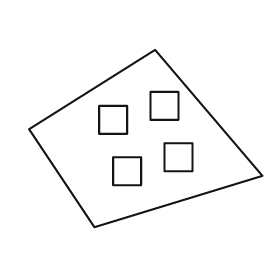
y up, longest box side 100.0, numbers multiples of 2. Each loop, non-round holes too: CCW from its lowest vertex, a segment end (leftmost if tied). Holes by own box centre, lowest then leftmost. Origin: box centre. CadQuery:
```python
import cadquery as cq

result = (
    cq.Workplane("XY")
    .moveTo(-22.0, -38.0)
    .lineTo(50.0, -16.0)
    .lineTo(4.0, 38.0)
    .lineTo(-50.0, 4.0)
    .close()
    .moveTo(-14.0, -20.0)
    .lineTo(-2.0, -20.0)
    .lineTo(-2.0, -8.0)
    .lineTo(-14.0, -8.0)
    .close()
    .moveTo(8.0, -14.0)
    .lineTo(20.0, -14.0)
    .lineTo(20.0, -2.0)
    .lineTo(8.0, -2.0)
    .close()
    .moveTo(-20.0, 2.0)
    .lineTo(-8.0, 2.0)
    .lineTo(-8.0, 14.0)
    .lineTo(-20.0, 14.0)
    .close()
    .moveTo(2.0, 8.0)
    .lineTo(14.0, 8.0)
    .lineTo(14.0, 20.0)
    .lineTo(2.0, 20.0)
    .close()
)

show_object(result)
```